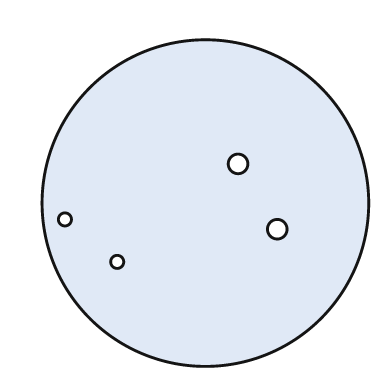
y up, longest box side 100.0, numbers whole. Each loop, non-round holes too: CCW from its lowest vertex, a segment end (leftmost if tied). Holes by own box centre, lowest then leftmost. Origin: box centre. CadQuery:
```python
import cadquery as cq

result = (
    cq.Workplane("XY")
    .moveTo(0.0, 0.0)
    .circle(50.0)
    .moveTo(-27.0, -18.0)
    .circle(2.0)
    .moveTo(22.0, -8.0)
    .circle(3.0)
    .moveTo(-43.0, -5.0)
    .circle(2.0)
    .moveTo(10.0, 12.0)
    .circle(3.0)
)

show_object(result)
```